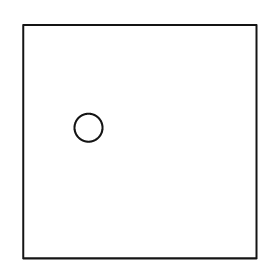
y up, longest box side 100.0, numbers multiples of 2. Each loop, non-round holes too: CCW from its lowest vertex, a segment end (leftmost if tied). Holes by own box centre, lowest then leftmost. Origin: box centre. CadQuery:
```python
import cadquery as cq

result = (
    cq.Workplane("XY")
    .moveTo(-50.0, -50.0)
    .lineTo(50.0, -50.0)
    .lineTo(50.0, 50.0)
    .lineTo(-50.0, 50.0)
    .close()
    .moveTo(-22.0, 6.0)
    .circle(6.0)
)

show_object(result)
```